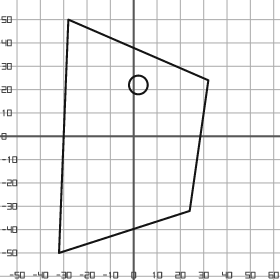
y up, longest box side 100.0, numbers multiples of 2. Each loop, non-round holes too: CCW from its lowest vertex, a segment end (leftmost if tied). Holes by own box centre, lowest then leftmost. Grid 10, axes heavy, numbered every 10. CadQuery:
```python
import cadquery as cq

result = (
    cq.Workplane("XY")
    .moveTo(-32.0, -50.0)
    .lineTo(24.0, -32.0)
    .lineTo(32.0, 24.0)
    .lineTo(-28.0, 50.0)
    .close()
    .moveTo(2.0, 22.0)
    .circle(4.0)
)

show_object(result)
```